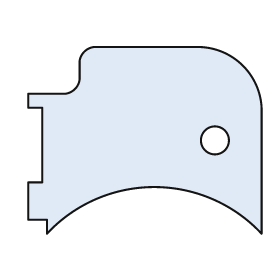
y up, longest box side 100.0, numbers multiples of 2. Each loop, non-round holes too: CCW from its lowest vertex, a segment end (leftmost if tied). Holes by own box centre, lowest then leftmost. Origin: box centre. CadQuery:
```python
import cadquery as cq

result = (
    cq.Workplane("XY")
    .moveTo(-42.0, -40.0)
    .threePointArc((4.0, -20.0), (50.0, -40.0))
    .lineTo(50.0, 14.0)
    .threePointArc((42.0, 32.0), (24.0, 40.0))
    .lineTo(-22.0, 40.0)
    .threePointArc((-26.0, 38.0), (-28.0, 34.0))
    .lineTo(-28.0, 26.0)
    .threePointArc((-30.0, 22.0), (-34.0, 20.0))
    .lineTo(-50.0, 20.0)
    .lineTo(-50.0, 14.0)
    .lineTo(-44.0, 14.0)
    .lineTo(-44.0, -18.0)
    .lineTo(-50.0, -18.0)
    .lineTo(-50.0, -34.0)
    .lineTo(-42.0, -34.0)
    .close()
    .moveTo(30.0, 0.0)
    .circle(6.0)
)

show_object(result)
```